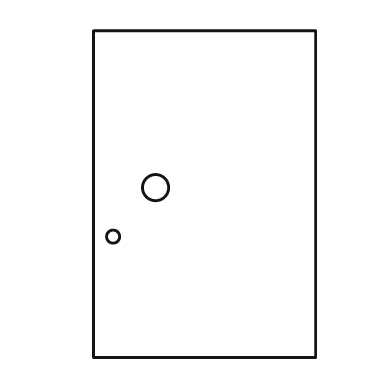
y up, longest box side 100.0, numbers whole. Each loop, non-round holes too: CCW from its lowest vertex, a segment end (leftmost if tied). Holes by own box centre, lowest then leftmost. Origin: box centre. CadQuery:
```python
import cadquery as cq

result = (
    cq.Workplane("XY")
    .moveTo(-34.0, -50.0)
    .lineTo(34.0, -50.0)
    .lineTo(34.0, 50.0)
    .lineTo(-34.0, 50.0)
    .close()
    .moveTo(-28.0, -13.0)
    .circle(2.0)
    .moveTo(-15.0, 2.0)
    .circle(4.0)
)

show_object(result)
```